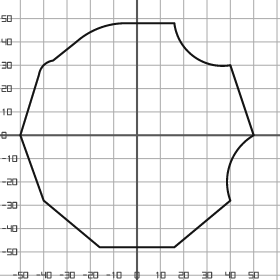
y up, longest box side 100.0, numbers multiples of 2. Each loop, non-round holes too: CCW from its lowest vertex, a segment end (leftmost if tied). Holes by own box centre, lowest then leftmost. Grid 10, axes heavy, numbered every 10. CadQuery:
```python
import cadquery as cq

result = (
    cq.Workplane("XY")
    .moveTo(-16.0, -48.0)
    .lineTo(16.0, -48.0)
    .lineTo(40.0, -28.0)
    .threePointArc((40.0, -12.0), (50.0, 0.0))
    .lineTo(40.0, 30.0)
    .threePointArc((24.0, 34.0), (16.0, 48.0))
    .lineTo(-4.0, 48.0)
    .threePointArc((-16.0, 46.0), (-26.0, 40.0))
    .lineTo(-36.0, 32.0)
    .threePointArc((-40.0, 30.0), (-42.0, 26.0))
    .lineTo(-50.0, 0.0)
    .lineTo(-40.0, -28.0)
    .close()
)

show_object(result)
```